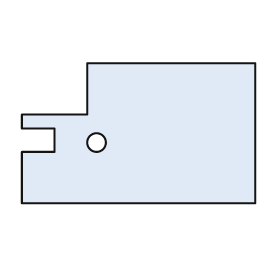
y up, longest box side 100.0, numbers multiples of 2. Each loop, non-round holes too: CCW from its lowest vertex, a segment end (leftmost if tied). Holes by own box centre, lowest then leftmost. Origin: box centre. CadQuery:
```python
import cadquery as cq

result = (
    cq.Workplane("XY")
    .moveTo(-50.0, -30.0)
    .lineTo(50.0, -30.0)
    .lineTo(50.0, 30.0)
    .lineTo(-22.0, 30.0)
    .lineTo(-22.0, 8.0)
    .lineTo(-50.0, 8.0)
    .lineTo(-50.0, 2.0)
    .lineTo(-36.0, 2.0)
    .lineTo(-36.0, -8.0)
    .lineTo(-50.0, -8.0)
    .close()
    .moveTo(-18.0, -4.0)
    .circle(4.0)
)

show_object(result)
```